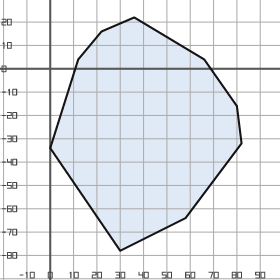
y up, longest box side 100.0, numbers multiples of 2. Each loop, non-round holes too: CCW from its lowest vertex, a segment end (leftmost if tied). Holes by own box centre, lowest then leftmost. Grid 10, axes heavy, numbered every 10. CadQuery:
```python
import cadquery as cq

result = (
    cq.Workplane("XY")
    .moveTo(30.0, -78.0)
    .lineTo(58.0, -64.0)
    .lineTo(82.0, -32.0)
    .lineTo(80.0, -16.0)
    .lineTo(66.0, 4.0)
    .lineTo(36.0, 22.0)
    .lineTo(22.0, 16.0)
    .lineTo(12.0, 4.0)
    .lineTo(0.0, -34.0)
    .close()
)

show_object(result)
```